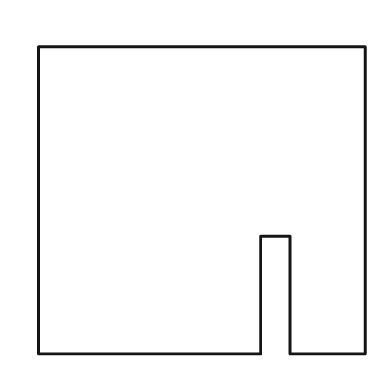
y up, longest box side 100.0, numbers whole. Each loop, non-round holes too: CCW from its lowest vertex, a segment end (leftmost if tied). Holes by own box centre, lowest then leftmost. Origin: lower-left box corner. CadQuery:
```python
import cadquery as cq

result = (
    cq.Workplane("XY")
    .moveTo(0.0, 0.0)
    .lineTo(68.0, 0.0)
    .lineTo(68.0, 36.0)
    .lineTo(77.0, 36.0)
    .lineTo(77.0, 0.0)
    .lineTo(100.0, 0.0)
    .lineTo(100.0, 94.0)
    .lineTo(0.0, 94.0)
    .close()
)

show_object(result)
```